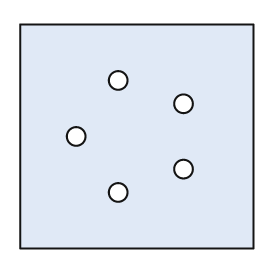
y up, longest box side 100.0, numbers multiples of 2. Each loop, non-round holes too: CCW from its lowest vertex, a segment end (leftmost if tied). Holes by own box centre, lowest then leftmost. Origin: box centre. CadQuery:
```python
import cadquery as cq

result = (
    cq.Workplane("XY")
    .moveTo(-50.0, -48.0)
    .lineTo(50.0, -48.0)
    .lineTo(50.0, 48.0)
    .lineTo(-50.0, 48.0)
    .close()
    .moveTo(-8.0, -24.0)
    .circle(4.0)
    .moveTo(20.0, -14.0)
    .circle(4.0)
    .moveTo(-26.0, 0.0)
    .circle(4.0)
    .moveTo(20.0, 14.0)
    .circle(4.0)
    .moveTo(-8.0, 24.0)
    .circle(4.0)
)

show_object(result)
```